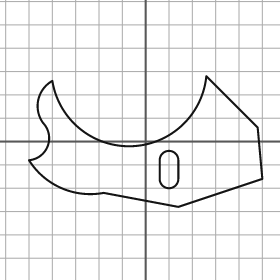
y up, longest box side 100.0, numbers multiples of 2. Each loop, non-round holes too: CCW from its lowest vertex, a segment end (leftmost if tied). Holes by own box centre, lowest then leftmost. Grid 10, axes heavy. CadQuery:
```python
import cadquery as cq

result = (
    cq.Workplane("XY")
    .moveTo(14.0, -28.0)
    .lineTo(50.0, -16.0)
    .lineTo(48.0, 6.0)
    .lineTo(26.0, 28.0)
    .threePointArc((-6.0, -2.0), (-40.0, 26.0))
    .threePointArc((-46.0, 18.0), (-44.0, 8.0))
    .threePointArc((-42.0, -2.0), (-50.0, -8.0))
    .threePointArc((-36.0, -20.0), (-18.0, -22.0))
    .close()
    .moveTo(6.0, -16.0)
    .threePointArc((10.0, -20.0), (14.0, -16.0))
    .lineTo(14.0, -8.0)
    .threePointArc((10.0, -4.0), (6.0, -8.0))
    .close()
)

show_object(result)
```